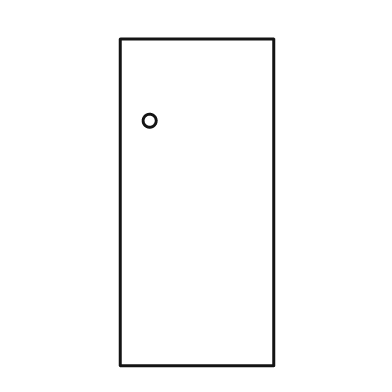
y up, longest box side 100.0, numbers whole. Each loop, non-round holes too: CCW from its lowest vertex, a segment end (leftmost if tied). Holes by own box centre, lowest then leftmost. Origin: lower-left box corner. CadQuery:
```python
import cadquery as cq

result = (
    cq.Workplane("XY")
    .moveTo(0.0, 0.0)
    .lineTo(47.0, 0.0)
    .lineTo(47.0, 100.0)
    .lineTo(0.0, 100.0)
    .close()
    .moveTo(9.0, 75.0)
    .circle(2.0)
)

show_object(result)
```